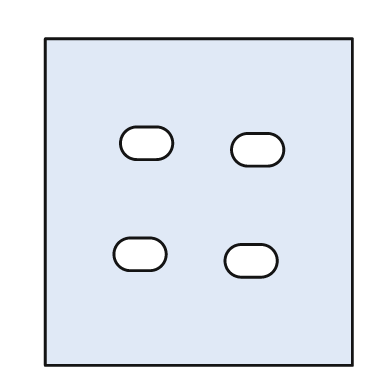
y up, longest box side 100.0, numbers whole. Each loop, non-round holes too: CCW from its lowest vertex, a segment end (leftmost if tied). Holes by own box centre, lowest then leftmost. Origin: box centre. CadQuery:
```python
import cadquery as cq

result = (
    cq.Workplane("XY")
    .moveTo(-47.0, -50.0)
    .lineTo(47.0, -50.0)
    .lineTo(47.0, 50.0)
    .lineTo(-47.0, 50.0)
    .close()
    .moveTo(13.0, -23.0)
    .lineTo(19.0, -23.0)
    .threePointArc((24.0, -18.0), (19.0, -13.0))
    .lineTo(13.0, -13.0)
    .threePointArc((8.0, -18.0), (13.0, -23.0))
    .close()
    .moveTo(-21.0, -21.0)
    .lineTo(-15.0, -21.0)
    .threePointArc((-10.0, -16.0), (-15.0, -11.0))
    .lineTo(-21.0, -11.0)
    .threePointArc((-26.0, -16.0), (-21.0, -21.0))
    .close()
    .moveTo(15.0, 11.0)
    .lineTo(21.0, 11.0)
    .threePointArc((26.0, 16.0), (21.0, 21.0))
    .lineTo(15.0, 21.0)
    .threePointArc((10.0, 16.0), (15.0, 11.0))
    .close()
    .moveTo(-19.0, 13.0)
    .lineTo(-13.0, 13.0)
    .threePointArc((-8.0, 18.0), (-13.0, 23.0))
    .lineTo(-19.0, 23.0)
    .threePointArc((-24.0, 18.0), (-19.0, 13.0))
    .close()
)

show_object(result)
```